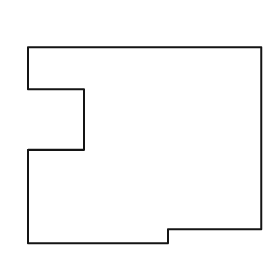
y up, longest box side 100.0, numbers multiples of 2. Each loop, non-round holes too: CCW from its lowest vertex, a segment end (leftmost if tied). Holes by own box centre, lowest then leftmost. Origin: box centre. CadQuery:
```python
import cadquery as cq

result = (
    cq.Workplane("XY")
    .moveTo(-50.0, -42.0)
    .lineTo(10.0, -42.0)
    .lineTo(10.0, -36.0)
    .lineTo(50.0, -36.0)
    .lineTo(50.0, 42.0)
    .lineTo(-50.0, 42.0)
    .lineTo(-50.0, 24.0)
    .lineTo(-26.0, 24.0)
    .lineTo(-26.0, -2.0)
    .lineTo(-50.0, -2.0)
    .close()
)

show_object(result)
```